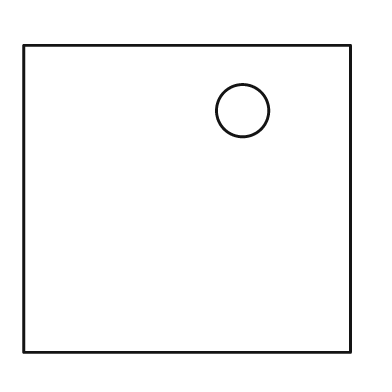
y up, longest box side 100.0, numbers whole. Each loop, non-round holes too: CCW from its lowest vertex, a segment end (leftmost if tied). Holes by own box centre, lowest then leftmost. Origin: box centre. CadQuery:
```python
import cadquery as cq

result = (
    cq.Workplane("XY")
    .moveTo(-50.0, -47.0)
    .lineTo(50.0, -47.0)
    .lineTo(50.0, 47.0)
    .lineTo(-50.0, 47.0)
    .close()
    .moveTo(17.0, 27.0)
    .circle(8.0)
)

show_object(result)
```